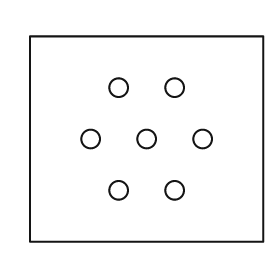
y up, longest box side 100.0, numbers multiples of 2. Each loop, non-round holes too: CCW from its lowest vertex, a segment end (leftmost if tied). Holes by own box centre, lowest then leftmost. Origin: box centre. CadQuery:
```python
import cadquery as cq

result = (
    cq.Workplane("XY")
    .moveTo(-50.0, -44.0)
    .lineTo(50.0, -44.0)
    .lineTo(50.0, 44.0)
    .lineTo(-50.0, 44.0)
    .close()
    .moveTo(-12.0, -22.0)
    .circle(4.0)
    .moveTo(12.0, -22.0)
    .circle(4.0)
    .moveTo(-24.0, 0.0)
    .circle(4.0)
    .moveTo(0.0, 0.0)
    .circle(4.0)
    .moveTo(24.0, 0.0)
    .circle(4.0)
    .moveTo(-12.0, 22.0)
    .circle(4.0)
    .moveTo(12.0, 22.0)
    .circle(4.0)
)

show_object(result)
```